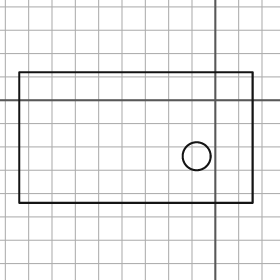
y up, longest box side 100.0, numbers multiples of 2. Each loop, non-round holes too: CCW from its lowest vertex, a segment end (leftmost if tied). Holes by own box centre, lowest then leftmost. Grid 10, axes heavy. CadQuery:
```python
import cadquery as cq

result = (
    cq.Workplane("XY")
    .moveTo(-84.0, -44.0)
    .lineTo(16.0, -44.0)
    .lineTo(16.0, 12.0)
    .lineTo(-84.0, 12.0)
    .close()
    .moveTo(-8.0, -24.0)
    .circle(6.0)
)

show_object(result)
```